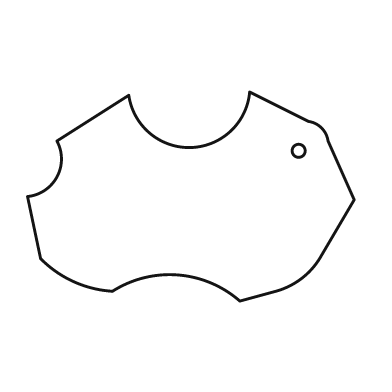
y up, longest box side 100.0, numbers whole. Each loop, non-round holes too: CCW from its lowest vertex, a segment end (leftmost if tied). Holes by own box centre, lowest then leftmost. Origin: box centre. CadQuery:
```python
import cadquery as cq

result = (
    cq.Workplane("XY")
    .moveTo(15.0, -32.0)
    .lineTo(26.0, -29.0)
    .threePointArc((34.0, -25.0), (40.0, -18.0))
    .lineTo(50.0, -1.0)
    .lineTo(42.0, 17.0)
    .threePointArc((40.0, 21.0), (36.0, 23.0))
    .lineTo(18.0, 32.0)
    .threePointArc((0.0, 15.0), (-19.0, 31.0))
    .lineTo(-41.0, 17.0)
    .threePointArc((-41.0, 6.0), (-50.0, 0.0))
    .lineTo(-46.0, -19.0)
    .threePointArc((-36.0, -26.0), (-24.0, -29.0))
    .threePointArc((-4.0, -24.0), (15.0, -32.0))
    .close()
    .moveTo(33.0, 14.0)
    .circle(2.0)
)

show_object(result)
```